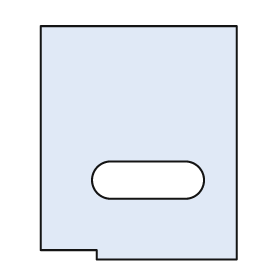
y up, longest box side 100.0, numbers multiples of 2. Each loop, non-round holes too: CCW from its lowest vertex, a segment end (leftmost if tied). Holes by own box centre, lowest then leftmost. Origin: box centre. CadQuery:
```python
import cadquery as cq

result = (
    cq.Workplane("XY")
    .moveTo(-18.0, -50.0)
    .lineTo(42.0, -50.0)
    .lineTo(42.0, 50.0)
    .lineTo(-42.0, 50.0)
    .lineTo(-42.0, -46.0)
    .lineTo(-18.0, -46.0)
    .close()
    .moveTo(-12.0, -24.0)
    .lineTo(20.0, -24.0)
    .threePointArc((28.0, -16.0), (20.0, -8.0))
    .lineTo(-12.0, -8.0)
    .threePointArc((-20.0, -16.0), (-12.0, -24.0))
    .close()
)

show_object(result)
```